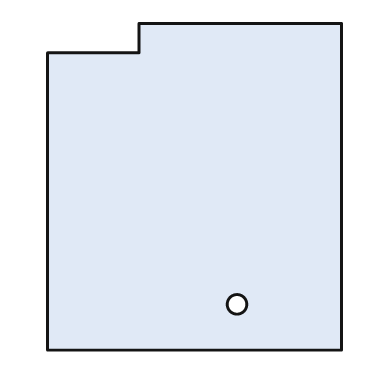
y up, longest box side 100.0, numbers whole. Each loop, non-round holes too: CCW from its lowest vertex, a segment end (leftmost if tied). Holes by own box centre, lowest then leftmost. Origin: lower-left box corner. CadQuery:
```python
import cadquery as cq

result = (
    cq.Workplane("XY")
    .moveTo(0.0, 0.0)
    .lineTo(90.0, 0.0)
    .lineTo(90.0, 100.0)
    .lineTo(28.0, 100.0)
    .lineTo(28.0, 91.0)
    .lineTo(0.0, 91.0)
    .close()
    .moveTo(58.0, 14.0)
    .circle(3.0)
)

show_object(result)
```